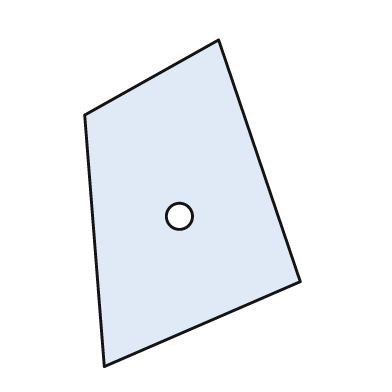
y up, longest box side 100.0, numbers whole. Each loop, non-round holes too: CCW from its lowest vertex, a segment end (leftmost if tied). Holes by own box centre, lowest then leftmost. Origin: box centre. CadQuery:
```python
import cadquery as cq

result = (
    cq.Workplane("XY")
    .moveTo(-27.0, -50.0)
    .lineTo(33.0, -24.0)
    .lineTo(8.0, 50.0)
    .lineTo(-33.0, 27.0)
    .close()
    .moveTo(-4.0, -4.0)
    .circle(4.0)
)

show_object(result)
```